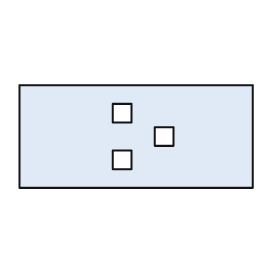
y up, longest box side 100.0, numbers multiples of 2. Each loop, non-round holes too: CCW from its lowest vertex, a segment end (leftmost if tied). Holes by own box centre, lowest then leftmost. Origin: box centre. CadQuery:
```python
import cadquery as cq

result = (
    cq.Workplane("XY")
    .moveTo(-50.0, -22.0)
    .lineTo(50.0, -22.0)
    .lineTo(50.0, 22.0)
    .lineTo(-50.0, 22.0)
    .close()
    .moveTo(-10.0, -14.0)
    .lineTo(-2.0, -14.0)
    .lineTo(-2.0, -6.0)
    .lineTo(-10.0, -6.0)
    .close()
    .moveTo(8.0, -4.0)
    .lineTo(16.0, -4.0)
    .lineTo(16.0, 4.0)
    .lineTo(8.0, 4.0)
    .close()
    .moveTo(-10.0, 6.0)
    .lineTo(-2.0, 6.0)
    .lineTo(-2.0, 14.0)
    .lineTo(-10.0, 14.0)
    .close()
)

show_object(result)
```